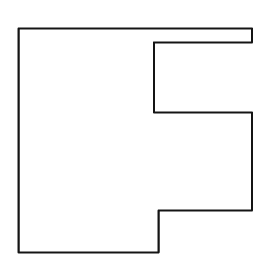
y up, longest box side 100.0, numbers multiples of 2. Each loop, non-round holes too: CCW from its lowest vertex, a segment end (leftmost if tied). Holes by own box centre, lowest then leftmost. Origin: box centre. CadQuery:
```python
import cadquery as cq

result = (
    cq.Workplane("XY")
    .moveTo(-50.0, -48.0)
    .lineTo(10.0, -48.0)
    .lineTo(10.0, -30.0)
    .lineTo(50.0, -30.0)
    .lineTo(50.0, 12.0)
    .lineTo(8.0, 12.0)
    .lineTo(8.0, 42.0)
    .lineTo(50.0, 42.0)
    .lineTo(50.0, 48.0)
    .lineTo(-50.0, 48.0)
    .close()
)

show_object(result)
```